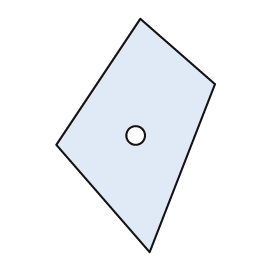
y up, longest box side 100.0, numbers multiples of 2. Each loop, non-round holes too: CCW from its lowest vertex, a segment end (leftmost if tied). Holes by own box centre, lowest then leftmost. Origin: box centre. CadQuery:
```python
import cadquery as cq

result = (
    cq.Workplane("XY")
    .moveTo(6.0, -50.0)
    .lineTo(34.0, 22.0)
    .lineTo(2.0, 50.0)
    .lineTo(-34.0, -4.0)
    .close()
    .moveTo(0.0, 0.0)
    .circle(4.0)
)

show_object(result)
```